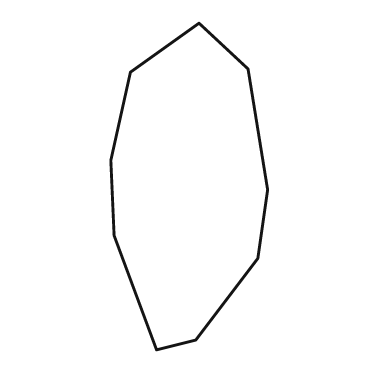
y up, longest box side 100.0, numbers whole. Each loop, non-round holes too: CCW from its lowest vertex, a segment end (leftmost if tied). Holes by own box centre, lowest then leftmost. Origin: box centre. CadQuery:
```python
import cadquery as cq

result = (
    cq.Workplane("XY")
    .moveTo(-10.0, -50.0)
    .lineTo(2.0, -47.0)
    .lineTo(21.0, -22.0)
    .lineTo(24.0, -1.0)
    .lineTo(18.0, 36.0)
    .lineTo(3.0, 50.0)
    .lineTo(-18.0, 35.0)
    .lineTo(-24.0, 8.0)
    .lineTo(-23.0, -15.0)
    .close()
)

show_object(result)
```